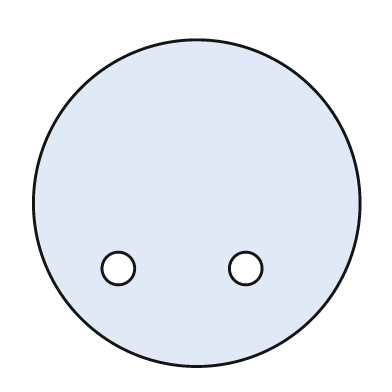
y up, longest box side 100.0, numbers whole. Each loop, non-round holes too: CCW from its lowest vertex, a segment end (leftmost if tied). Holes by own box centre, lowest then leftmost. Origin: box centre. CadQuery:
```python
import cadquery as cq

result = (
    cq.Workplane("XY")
    .moveTo(0.0, 0.0)
    .circle(50.0)
    .moveTo(-24.0, -20.0)
    .circle(5.0)
    .moveTo(15.0, -20.0)
    .circle(5.0)
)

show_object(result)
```